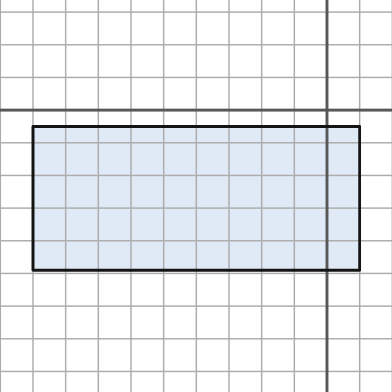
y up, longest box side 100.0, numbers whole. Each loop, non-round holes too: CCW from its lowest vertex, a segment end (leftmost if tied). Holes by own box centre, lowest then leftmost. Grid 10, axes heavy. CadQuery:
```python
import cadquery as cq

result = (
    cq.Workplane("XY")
    .moveTo(-90.0, -49.0)
    .lineTo(10.0, -49.0)
    .lineTo(10.0, -5.0)
    .lineTo(-90.0, -5.0)
    .close()
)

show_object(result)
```